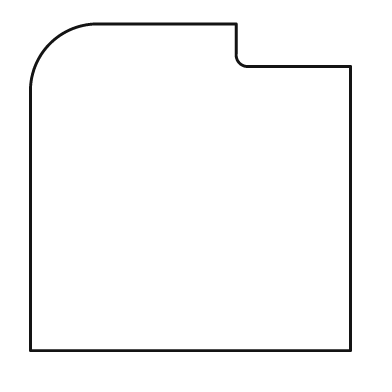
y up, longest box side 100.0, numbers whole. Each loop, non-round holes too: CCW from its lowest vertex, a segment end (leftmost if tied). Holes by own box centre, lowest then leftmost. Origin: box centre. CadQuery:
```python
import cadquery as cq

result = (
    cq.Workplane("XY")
    .moveTo(-49.0, -50.0)
    .lineTo(49.0, -50.0)
    .lineTo(49.0, 37.0)
    .lineTo(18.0, 37.0)
    .threePointArc((15.0, 38.0), (14.0, 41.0))
    .lineTo(14.0, 50.0)
    .lineTo(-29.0, 50.0)
    .threePointArc((-43.0, 44.0), (-49.0, 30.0))
    .close()
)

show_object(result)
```